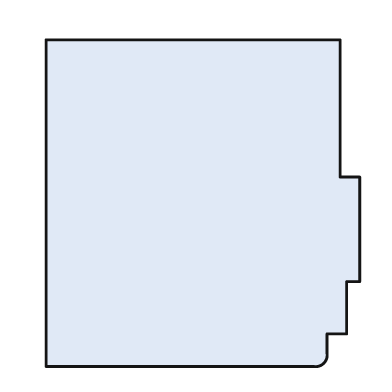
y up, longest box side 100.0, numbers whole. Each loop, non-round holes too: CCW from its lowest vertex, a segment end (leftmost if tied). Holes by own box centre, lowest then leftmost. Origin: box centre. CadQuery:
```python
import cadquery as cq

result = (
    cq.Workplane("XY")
    .moveTo(-48.0, -50.0)
    .lineTo(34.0, -50.0)
    .threePointArc((37.0, -49.0), (38.0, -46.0))
    .lineTo(38.0, -40.0)
    .lineTo(44.0, -40.0)
    .lineTo(44.0, -24.0)
    .lineTo(48.0, -24.0)
    .lineTo(48.0, 8.0)
    .lineTo(42.0, 8.0)
    .lineTo(42.0, 50.0)
    .lineTo(-48.0, 50.0)
    .close()
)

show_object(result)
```